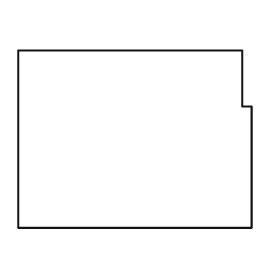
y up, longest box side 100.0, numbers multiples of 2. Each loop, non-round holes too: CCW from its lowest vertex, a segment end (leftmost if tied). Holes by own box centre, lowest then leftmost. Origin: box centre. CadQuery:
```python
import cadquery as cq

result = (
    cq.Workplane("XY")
    .moveTo(-50.0, -38.0)
    .lineTo(50.0, -38.0)
    .lineTo(50.0, 14.0)
    .lineTo(46.0, 14.0)
    .lineTo(46.0, 38.0)
    .lineTo(-50.0, 38.0)
    .close()
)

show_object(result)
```